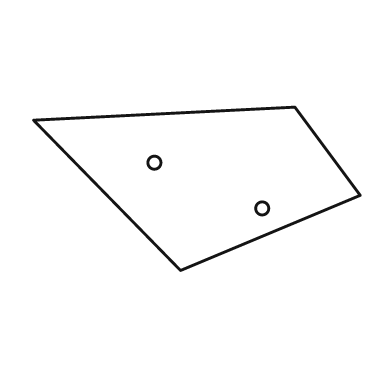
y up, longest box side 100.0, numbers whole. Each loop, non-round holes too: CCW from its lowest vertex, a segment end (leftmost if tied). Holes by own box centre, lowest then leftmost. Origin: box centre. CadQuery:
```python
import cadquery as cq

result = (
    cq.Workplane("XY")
    .moveTo(-5.0, -25.0)
    .lineTo(50.0, -2.0)
    .lineTo(30.0, 25.0)
    .lineTo(-50.0, 21.0)
    .close()
    .moveTo(20.0, -6.0)
    .circle(2.0)
    .moveTo(-13.0, 8.0)
    .circle(2.0)
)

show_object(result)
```